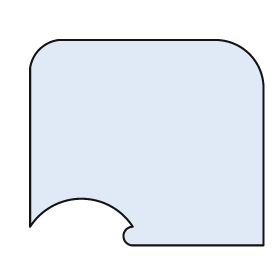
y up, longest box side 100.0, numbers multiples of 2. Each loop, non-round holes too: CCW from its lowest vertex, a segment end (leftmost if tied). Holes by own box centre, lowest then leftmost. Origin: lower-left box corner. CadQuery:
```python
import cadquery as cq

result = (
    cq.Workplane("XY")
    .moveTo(44.0, 0.0)
    .lineTo(100.0, 0.0)
    .lineTo(100.0, 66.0)
    .threePointArc((94.0, 82.0), (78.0, 88.0))
    .lineTo(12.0, 88.0)
    .threePointArc((4.0, 84.0), (0.0, 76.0))
    .lineTo(0.0, 8.0)
    .threePointArc((22.0, 20.0), (44.0, 8.0))
    .threePointArc((40.0, 4.0), (44.0, 0.0))
    .close()
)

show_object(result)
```